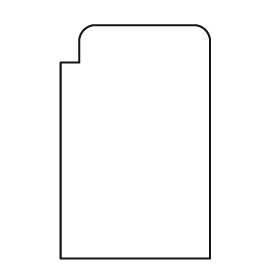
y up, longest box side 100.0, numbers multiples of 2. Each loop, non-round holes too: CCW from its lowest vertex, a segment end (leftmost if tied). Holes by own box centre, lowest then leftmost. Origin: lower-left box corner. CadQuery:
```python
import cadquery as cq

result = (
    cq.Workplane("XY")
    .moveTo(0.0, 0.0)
    .lineTo(64.0, 0.0)
    .lineTo(64.0, 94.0)
    .threePointArc((62.0, 98.0), (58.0, 100.0))
    .lineTo(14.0, 100.0)
    .threePointArc((10.0, 98.0), (8.0, 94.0))
    .lineTo(8.0, 84.0)
    .lineTo(0.0, 84.0)
    .close()
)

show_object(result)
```